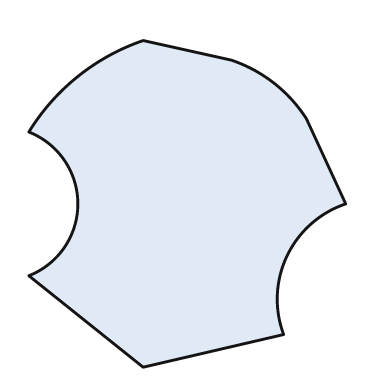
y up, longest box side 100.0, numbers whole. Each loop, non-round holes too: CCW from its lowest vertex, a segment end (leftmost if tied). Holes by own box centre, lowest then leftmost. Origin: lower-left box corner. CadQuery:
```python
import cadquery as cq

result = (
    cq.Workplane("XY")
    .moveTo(35.0, 0.0)
    .lineTo(78.0, 10.0)
    .threePointArc((79.0, 34.0), (97.0, 50.0))
    .lineTo(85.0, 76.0)
    .threePointArc((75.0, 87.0), (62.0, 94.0))
    .lineTo(35.0, 100.0)
    .threePointArc((15.0, 89.0), (0.0, 72.0))
    .threePointArc((15.0, 50.0), (0.0, 28.0))
    .close()
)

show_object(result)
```